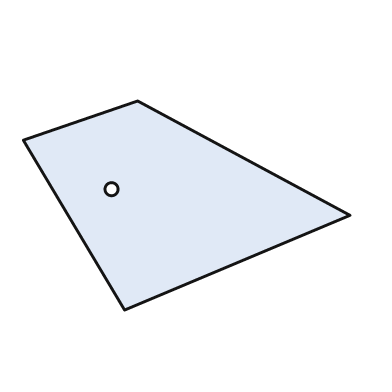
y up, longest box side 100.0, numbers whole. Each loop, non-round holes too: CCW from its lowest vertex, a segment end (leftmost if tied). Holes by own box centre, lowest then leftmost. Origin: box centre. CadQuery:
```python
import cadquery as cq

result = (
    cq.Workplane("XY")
    .moveTo(-19.0, -32.0)
    .lineTo(50.0, -3.0)
    .lineTo(-15.0, 32.0)
    .lineTo(-50.0, 20.0)
    .close()
    .moveTo(-23.0, 5.0)
    .circle(2.0)
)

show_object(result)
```